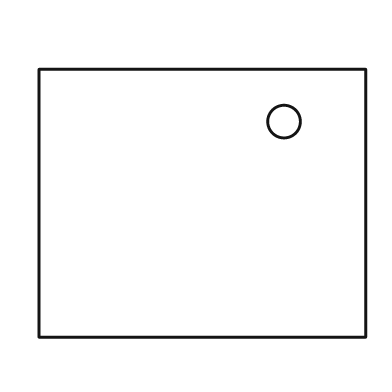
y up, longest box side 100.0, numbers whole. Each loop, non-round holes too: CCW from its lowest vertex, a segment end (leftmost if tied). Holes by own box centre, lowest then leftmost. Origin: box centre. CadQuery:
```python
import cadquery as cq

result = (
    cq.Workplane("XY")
    .moveTo(-50.0, -41.0)
    .lineTo(50.0, -41.0)
    .lineTo(50.0, 41.0)
    .lineTo(-50.0, 41.0)
    .close()
    .moveTo(25.0, 25.0)
    .circle(5.0)
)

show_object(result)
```